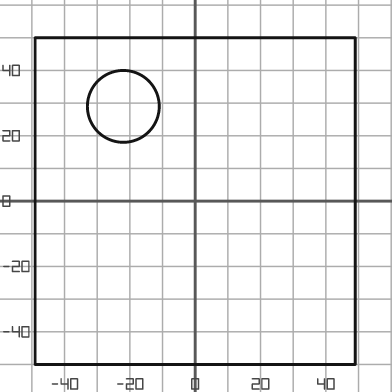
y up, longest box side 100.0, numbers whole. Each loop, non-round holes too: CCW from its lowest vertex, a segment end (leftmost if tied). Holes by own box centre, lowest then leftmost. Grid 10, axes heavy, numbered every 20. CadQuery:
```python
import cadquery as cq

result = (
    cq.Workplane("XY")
    .moveTo(-49.0, -50.0)
    .lineTo(49.0, -50.0)
    .lineTo(49.0, 50.0)
    .lineTo(-49.0, 50.0)
    .close()
    .moveTo(-22.0, 29.0)
    .circle(11.0)
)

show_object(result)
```